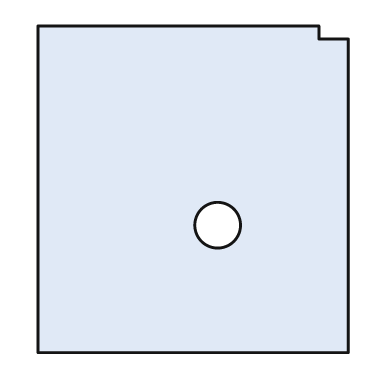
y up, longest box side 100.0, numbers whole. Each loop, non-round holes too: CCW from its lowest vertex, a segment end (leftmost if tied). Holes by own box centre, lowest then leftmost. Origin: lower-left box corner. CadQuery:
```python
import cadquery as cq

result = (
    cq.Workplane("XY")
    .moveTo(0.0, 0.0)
    .lineTo(95.0, 0.0)
    .lineTo(95.0, 96.0)
    .lineTo(86.0, 96.0)
    .lineTo(86.0, 100.0)
    .lineTo(0.0, 100.0)
    .close()
    .moveTo(55.0, 39.0)
    .circle(7.0)
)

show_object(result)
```